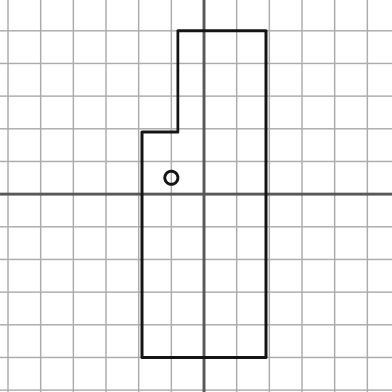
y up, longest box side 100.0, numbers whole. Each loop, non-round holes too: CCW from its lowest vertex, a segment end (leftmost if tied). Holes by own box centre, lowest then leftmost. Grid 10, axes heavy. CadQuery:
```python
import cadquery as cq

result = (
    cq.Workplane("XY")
    .moveTo(-19.0, -50.0)
    .lineTo(19.0, -50.0)
    .lineTo(19.0, 50.0)
    .lineTo(-8.0, 50.0)
    .lineTo(-8.0, 19.0)
    .lineTo(-19.0, 19.0)
    .close()
    .moveTo(-10.0, 5.0)
    .circle(2.0)
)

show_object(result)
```